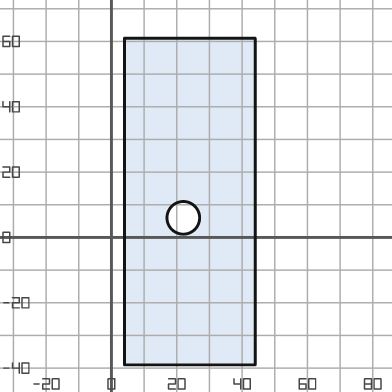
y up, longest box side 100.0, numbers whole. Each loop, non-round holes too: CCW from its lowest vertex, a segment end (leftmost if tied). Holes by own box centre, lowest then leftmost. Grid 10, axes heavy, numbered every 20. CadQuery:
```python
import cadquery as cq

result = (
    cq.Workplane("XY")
    .moveTo(4.0, -39.0)
    .lineTo(44.0, -39.0)
    .lineTo(44.0, 61.0)
    .lineTo(4.0, 61.0)
    .close()
    .moveTo(22.0, 6.0)
    .circle(5.0)
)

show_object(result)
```